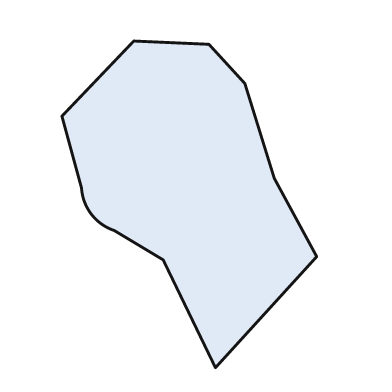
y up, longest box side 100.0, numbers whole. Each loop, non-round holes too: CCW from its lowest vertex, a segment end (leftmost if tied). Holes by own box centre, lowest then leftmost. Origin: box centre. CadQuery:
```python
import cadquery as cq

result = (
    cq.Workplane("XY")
    .moveTo(8.0, -50.0)
    .lineTo(39.0, -16.0)
    .lineTo(26.0, 8.0)
    .lineTo(17.0, 37.0)
    .lineTo(6.0, 49.0)
    .lineTo(-17.0, 50.0)
    .lineTo(-39.0, 27.0)
    .lineTo(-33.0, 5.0)
    .threePointArc((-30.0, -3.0), (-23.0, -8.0))
    .lineTo(-8.0, -17.0)
    .close()
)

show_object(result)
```